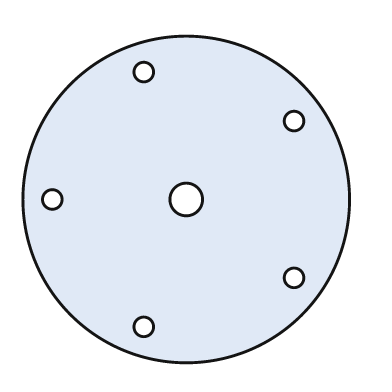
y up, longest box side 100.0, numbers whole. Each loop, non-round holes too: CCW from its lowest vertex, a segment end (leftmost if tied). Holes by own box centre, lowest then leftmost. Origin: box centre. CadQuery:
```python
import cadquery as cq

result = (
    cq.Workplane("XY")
    .moveTo(0.0, 0.0)
    .circle(50.0)
    .moveTo(-13.0, -39.0)
    .circle(3.0)
    .moveTo(33.0, -24.0)
    .circle(3.0)
    .moveTo(-41.0, 0.0)
    .circle(3.0)
    .moveTo(0.0, 0.0)
    .circle(5.0)
    .moveTo(33.0, 24.0)
    .circle(3.0)
    .moveTo(-13.0, 39.0)
    .circle(3.0)
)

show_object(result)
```